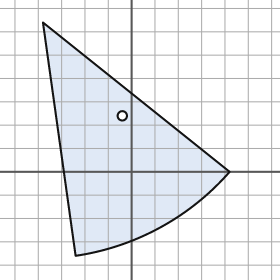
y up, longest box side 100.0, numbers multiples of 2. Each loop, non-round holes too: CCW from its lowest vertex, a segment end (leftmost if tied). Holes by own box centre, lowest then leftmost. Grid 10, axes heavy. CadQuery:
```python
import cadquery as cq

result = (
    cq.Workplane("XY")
    .moveTo(-24.0, -36.0)
    .threePointArc((12.0, -24.0), (42.0, 0.0))
    .lineTo(-38.0, 64.0)
    .close()
    .moveTo(-4.0, 24.0)
    .circle(2.0)
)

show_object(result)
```